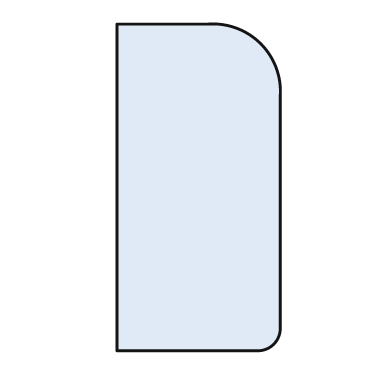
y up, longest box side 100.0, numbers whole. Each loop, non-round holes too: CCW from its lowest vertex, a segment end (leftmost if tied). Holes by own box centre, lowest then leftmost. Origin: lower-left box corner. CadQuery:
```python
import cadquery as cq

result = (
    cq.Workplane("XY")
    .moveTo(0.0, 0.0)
    .lineTo(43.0, 0.0)
    .threePointArc((48.0, 2.0), (50.0, 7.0))
    .lineTo(50.0, 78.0)
    .threePointArc((44.0, 94.0), (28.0, 100.0))
    .lineTo(0.0, 100.0)
    .close()
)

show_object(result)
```